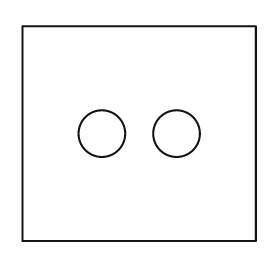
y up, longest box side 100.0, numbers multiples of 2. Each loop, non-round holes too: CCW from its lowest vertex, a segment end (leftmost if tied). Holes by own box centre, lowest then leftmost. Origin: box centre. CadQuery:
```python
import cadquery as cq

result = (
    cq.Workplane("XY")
    .moveTo(-50.0, -46.0)
    .lineTo(50.0, -46.0)
    .lineTo(50.0, 46.0)
    .lineTo(-50.0, 46.0)
    .close()
    .moveTo(-16.0, 0.0)
    .circle(10.0)
    .moveTo(16.0, 0.0)
    .circle(10.0)
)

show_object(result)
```